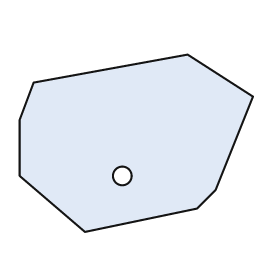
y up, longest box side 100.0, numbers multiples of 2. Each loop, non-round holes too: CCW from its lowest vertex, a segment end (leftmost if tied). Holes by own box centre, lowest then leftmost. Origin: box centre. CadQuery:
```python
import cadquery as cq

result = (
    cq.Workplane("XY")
    .moveTo(-22.0, -38.0)
    .lineTo(26.0, -28.0)
    .lineTo(34.0, -20.0)
    .lineTo(50.0, 20.0)
    .lineTo(22.0, 38.0)
    .lineTo(-44.0, 26.0)
    .lineTo(-50.0, 10.0)
    .lineTo(-50.0, -14.0)
    .close()
    .moveTo(-6.0, -14.0)
    .circle(4.0)
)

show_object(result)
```